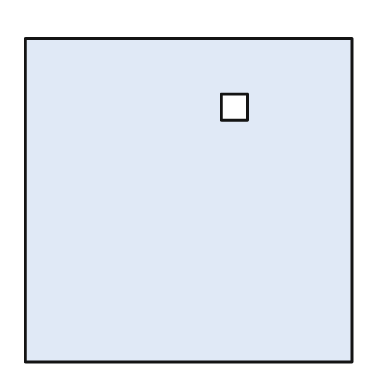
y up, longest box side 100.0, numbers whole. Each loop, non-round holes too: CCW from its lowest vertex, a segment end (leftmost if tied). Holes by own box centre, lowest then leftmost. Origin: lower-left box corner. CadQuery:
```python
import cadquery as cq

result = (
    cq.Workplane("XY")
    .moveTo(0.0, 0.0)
    .lineTo(100.0, 0.0)
    .lineTo(100.0, 99.0)
    .lineTo(0.0, 99.0)
    .close()
    .moveTo(60.0, 74.0)
    .lineTo(68.0, 74.0)
    .lineTo(68.0, 82.0)
    .lineTo(60.0, 82.0)
    .close()
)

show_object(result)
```